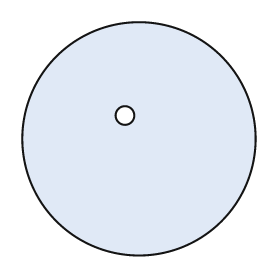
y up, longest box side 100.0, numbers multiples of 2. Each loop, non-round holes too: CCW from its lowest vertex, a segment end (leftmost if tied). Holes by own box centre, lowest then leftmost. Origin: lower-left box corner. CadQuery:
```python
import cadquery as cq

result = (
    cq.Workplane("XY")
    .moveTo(50.0, 50.0)
    .circle(50.0)
    .moveTo(44.0, 60.0)
    .circle(4.0)
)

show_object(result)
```